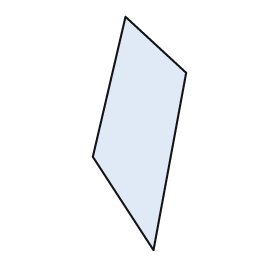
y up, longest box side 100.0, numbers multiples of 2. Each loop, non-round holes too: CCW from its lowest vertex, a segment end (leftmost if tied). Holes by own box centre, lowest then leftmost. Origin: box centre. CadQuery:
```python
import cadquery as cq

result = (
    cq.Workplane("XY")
    .moveTo(6.0, -50.0)
    .lineTo(20.0, 26.0)
    .lineTo(-6.0, 50.0)
    .lineTo(-20.0, -10.0)
    .close()
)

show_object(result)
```